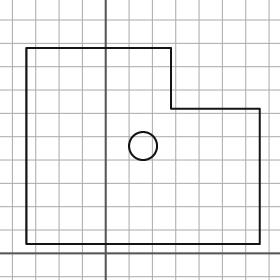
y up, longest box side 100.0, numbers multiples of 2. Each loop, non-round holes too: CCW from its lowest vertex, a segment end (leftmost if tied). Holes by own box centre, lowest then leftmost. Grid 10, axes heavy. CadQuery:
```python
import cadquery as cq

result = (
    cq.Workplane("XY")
    .moveTo(-34.0, 4.0)
    .lineTo(66.0, 4.0)
    .lineTo(66.0, 62.0)
    .lineTo(28.0, 62.0)
    .lineTo(28.0, 88.0)
    .lineTo(-34.0, 88.0)
    .close()
    .moveTo(16.0, 46.0)
    .circle(6.0)
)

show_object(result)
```